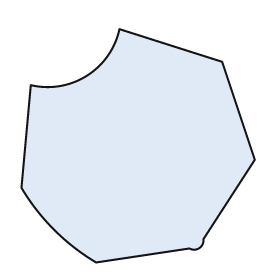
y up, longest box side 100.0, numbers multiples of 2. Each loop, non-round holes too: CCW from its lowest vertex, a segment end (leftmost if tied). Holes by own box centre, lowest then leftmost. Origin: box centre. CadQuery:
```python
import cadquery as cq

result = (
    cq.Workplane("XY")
    .moveTo(-18.0, -50.0)
    .lineTo(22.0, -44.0)
    .threePointArc((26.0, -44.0), (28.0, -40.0))
    .lineTo(50.0, -6.0)
    .lineTo(36.0, 36.0)
    .lineTo(-8.0, 50.0)
    .threePointArc((-22.0, 30.0), (-46.0, 26.0))
    .lineTo(-50.0, -18.0)
    .threePointArc((-36.0, -36.0), (-18.0, -50.0))
    .close()
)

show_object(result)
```